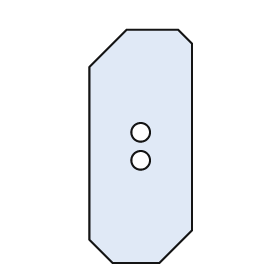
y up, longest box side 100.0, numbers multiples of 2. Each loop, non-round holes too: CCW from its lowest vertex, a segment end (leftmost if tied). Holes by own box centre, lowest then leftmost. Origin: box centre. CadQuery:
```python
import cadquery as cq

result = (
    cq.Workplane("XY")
    .moveTo(-12.0, -50.0)
    .lineTo(8.0, -50.0)
    .lineTo(22.0, -36.0)
    .lineTo(22.0, 44.0)
    .lineTo(16.0, 50.0)
    .lineTo(-6.0, 50.0)
    .lineTo(-22.0, 34.0)
    .lineTo(-22.0, -40.0)
    .close()
    .moveTo(0.0, -6.0)
    .circle(4.0)
    .moveTo(0.0, 6.0)
    .circle(4.0)
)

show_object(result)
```